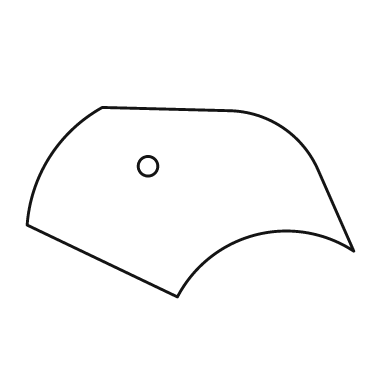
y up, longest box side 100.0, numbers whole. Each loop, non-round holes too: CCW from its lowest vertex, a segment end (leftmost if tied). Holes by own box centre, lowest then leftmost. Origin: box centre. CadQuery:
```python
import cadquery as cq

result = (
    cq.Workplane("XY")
    .moveTo(-4.0, -29.0)
    .threePointArc((20.0, -10.0), (50.0, -15.0))
    .lineTo(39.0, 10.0)
    .threePointArc((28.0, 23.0), (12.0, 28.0))
    .lineTo(-27.0, 29.0)
    .threePointArc((-43.0, 14.0), (-50.0, -7.0))
    .close()
    .moveTo(-13.0, 11.0)
    .circle(3.0)
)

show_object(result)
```